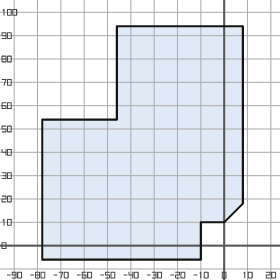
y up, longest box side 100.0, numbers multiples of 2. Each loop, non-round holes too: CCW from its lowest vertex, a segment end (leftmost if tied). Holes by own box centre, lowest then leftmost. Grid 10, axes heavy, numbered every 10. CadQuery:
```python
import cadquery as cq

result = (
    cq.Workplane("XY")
    .moveTo(-78.0, -6.0)
    .lineTo(-10.0, -6.0)
    .lineTo(-10.0, 10.0)
    .lineTo(0.0, 10.0)
    .lineTo(8.0, 18.0)
    .lineTo(8.0, 94.0)
    .lineTo(-46.0, 94.0)
    .lineTo(-46.0, 54.0)
    .lineTo(-78.0, 54.0)
    .close()
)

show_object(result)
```